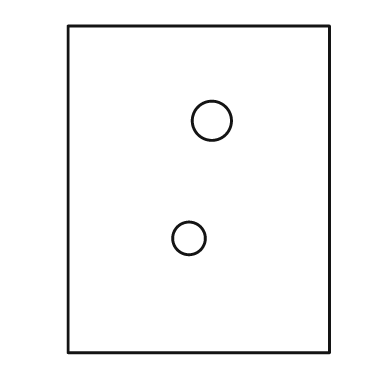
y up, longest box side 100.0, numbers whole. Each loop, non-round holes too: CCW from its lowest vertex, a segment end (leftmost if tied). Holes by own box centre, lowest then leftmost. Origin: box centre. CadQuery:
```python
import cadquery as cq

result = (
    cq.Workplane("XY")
    .moveTo(-40.0, -50.0)
    .lineTo(40.0, -50.0)
    .lineTo(40.0, 50.0)
    .lineTo(-40.0, 50.0)
    .close()
    .moveTo(-3.0, -15.0)
    .circle(5.0)
    .moveTo(4.0, 21.0)
    .circle(6.0)
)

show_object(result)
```